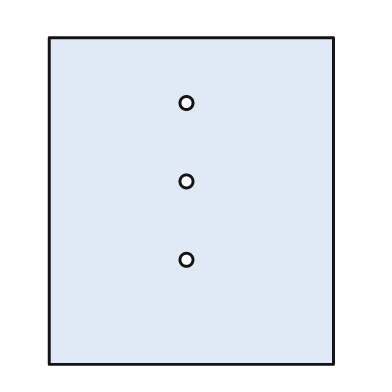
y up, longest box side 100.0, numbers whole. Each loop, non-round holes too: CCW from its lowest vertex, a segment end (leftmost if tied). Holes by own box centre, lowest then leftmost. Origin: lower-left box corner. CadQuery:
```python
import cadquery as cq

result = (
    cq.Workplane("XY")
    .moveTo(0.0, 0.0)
    .lineTo(87.0, 0.0)
    .lineTo(87.0, 100.0)
    .lineTo(0.0, 100.0)
    .close()
    .moveTo(42.0, 32.0)
    .circle(2.0)
    .moveTo(42.0, 56.0)
    .circle(2.0)
    .moveTo(42.0, 80.0)
    .circle(2.0)
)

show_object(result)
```